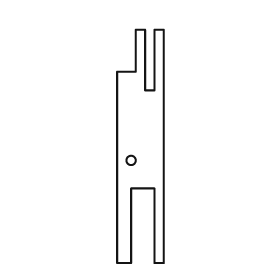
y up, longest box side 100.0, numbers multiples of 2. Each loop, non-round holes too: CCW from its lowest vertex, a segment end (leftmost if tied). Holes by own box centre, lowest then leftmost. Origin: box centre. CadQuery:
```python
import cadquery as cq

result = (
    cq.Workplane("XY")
    .moveTo(-10.0, -50.0)
    .lineTo(-4.0, -50.0)
    .lineTo(-4.0, -18.0)
    .lineTo(6.0, -18.0)
    .lineTo(6.0, -50.0)
    .lineTo(10.0, -50.0)
    .lineTo(10.0, 50.0)
    .lineTo(6.0, 50.0)
    .lineTo(6.0, 24.0)
    .lineTo(2.0, 24.0)
    .lineTo(2.0, 50.0)
    .lineTo(-2.0, 50.0)
    .lineTo(-2.0, 32.0)
    .lineTo(-10.0, 32.0)
    .close()
    .moveTo(-4.0, -6.0)
    .circle(2.0)
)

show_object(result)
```